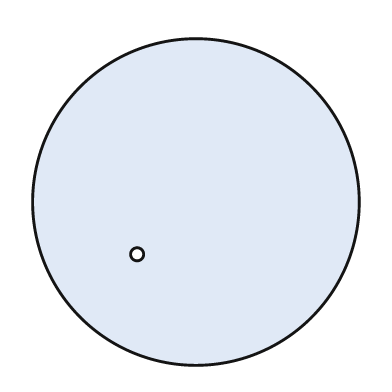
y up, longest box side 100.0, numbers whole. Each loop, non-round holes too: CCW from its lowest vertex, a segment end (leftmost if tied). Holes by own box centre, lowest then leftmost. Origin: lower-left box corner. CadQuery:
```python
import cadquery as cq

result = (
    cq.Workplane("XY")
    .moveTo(50.0, 50.0)
    .circle(50.0)
    .moveTo(32.0, 34.0)
    .circle(2.0)
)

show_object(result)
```